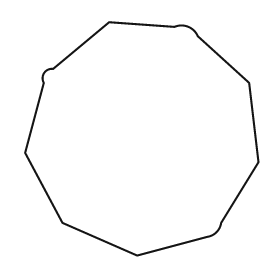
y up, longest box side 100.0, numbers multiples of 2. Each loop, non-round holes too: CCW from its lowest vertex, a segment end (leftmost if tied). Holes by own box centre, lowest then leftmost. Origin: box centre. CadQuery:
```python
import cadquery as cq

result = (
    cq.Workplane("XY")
    .moveTo(-2.0, -50.0)
    .lineTo(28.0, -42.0)
    .threePointArc((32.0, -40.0), (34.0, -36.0))
    .lineTo(50.0, -10.0)
    .lineTo(46.0, 24.0)
    .lineTo(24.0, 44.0)
    .threePointArc((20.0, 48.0), (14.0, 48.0))
    .lineTo(-14.0, 50.0)
    .lineTo(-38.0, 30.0)
    .threePointArc((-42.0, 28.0), (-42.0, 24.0))
    .lineTo(-50.0, -6.0)
    .lineTo(-34.0, -36.0)
    .close()
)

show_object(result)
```